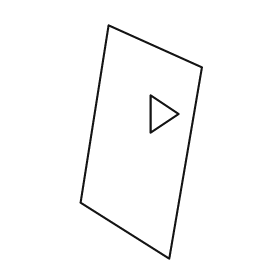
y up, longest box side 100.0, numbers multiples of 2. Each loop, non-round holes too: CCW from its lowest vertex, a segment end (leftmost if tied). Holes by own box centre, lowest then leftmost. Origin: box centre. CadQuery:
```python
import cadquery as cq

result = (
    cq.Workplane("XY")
    .moveTo(12.0, -50.0)
    .lineTo(26.0, 32.0)
    .lineTo(-14.0, 50.0)
    .lineTo(-26.0, -26.0)
    .close()
    .moveTo(4.0, 4.0)
    .lineTo(16.0, 12.0)
    .lineTo(4.0, 20.0)
    .close()
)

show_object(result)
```